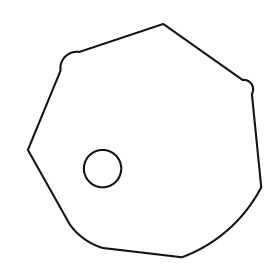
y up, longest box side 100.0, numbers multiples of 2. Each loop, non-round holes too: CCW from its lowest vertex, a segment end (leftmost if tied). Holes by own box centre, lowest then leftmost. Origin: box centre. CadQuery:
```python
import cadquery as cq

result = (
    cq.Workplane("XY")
    .moveTo(16.0, -50.0)
    .threePointArc((36.0, -38.0), (50.0, -20.0))
    .lineTo(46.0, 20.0)
    .threePointArc((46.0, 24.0), (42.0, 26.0))
    .lineTo(8.0, 50.0)
    .lineTo(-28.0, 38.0)
    .threePointArc((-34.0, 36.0), (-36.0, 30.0))
    .lineTo(-50.0, -4.0)
    .lineTo(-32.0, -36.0)
    .threePointArc((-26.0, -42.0), (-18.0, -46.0))
    .close()
    .moveTo(-18.0, -12.0)
    .circle(8.0)
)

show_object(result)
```